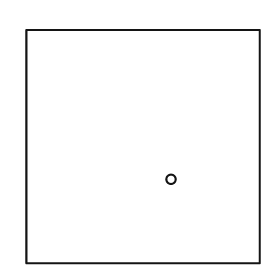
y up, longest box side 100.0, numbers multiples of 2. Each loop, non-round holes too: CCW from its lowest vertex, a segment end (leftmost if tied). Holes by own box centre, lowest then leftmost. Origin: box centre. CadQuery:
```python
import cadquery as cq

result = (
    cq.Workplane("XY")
    .moveTo(-50.0, -50.0)
    .lineTo(50.0, -50.0)
    .lineTo(50.0, 50.0)
    .lineTo(-50.0, 50.0)
    .close()
    .moveTo(12.0, -14.0)
    .circle(2.0)
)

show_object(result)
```